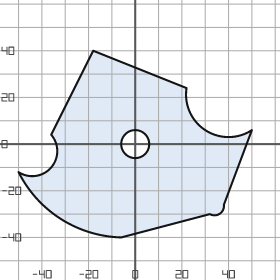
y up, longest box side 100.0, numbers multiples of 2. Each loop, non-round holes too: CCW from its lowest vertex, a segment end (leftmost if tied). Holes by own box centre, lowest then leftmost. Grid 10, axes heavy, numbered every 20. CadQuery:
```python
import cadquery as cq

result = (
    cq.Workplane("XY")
    .moveTo(-6.0, -40.0)
    .lineTo(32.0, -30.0)
    .threePointArc((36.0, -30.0), (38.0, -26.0))
    .lineTo(50.0, 6.0)
    .threePointArc((30.0, 6.0), (22.0, 24.0))
    .lineTo(-18.0, 40.0)
    .lineTo(-36.0, 4.0)
    .threePointArc((-36.0, -10.0), (-50.0, -12.0))
    .threePointArc((-32.0, -32.0), (-6.0, -40.0))
    .close()
    .moveTo(0.0, 0.0)
    .circle(6.0)
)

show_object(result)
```